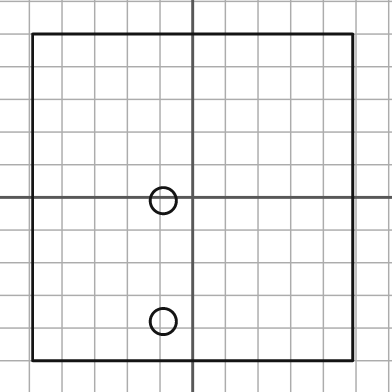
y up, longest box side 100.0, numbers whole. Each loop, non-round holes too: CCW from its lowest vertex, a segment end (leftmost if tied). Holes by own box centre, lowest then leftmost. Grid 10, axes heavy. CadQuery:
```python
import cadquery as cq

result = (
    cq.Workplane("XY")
    .moveTo(-49.0, -50.0)
    .lineTo(49.0, -50.0)
    .lineTo(49.0, 50.0)
    .lineTo(-49.0, 50.0)
    .close()
    .moveTo(-9.0, -38.0)
    .circle(4.0)
    .moveTo(-9.0, -1.0)
    .circle(4.0)
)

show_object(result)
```